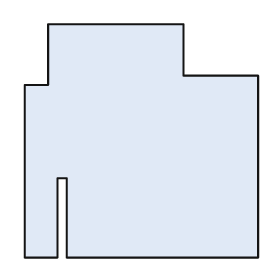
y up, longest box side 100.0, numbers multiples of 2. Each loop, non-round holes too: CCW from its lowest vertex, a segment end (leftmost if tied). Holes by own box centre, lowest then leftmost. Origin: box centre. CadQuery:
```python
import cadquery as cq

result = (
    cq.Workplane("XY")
    .moveTo(-50.0, -50.0)
    .lineTo(-36.0, -50.0)
    .lineTo(-36.0, -16.0)
    .lineTo(-32.0, -16.0)
    .lineTo(-32.0, -50.0)
    .lineTo(50.0, -50.0)
    .lineTo(50.0, 28.0)
    .lineTo(18.0, 28.0)
    .lineTo(18.0, 50.0)
    .lineTo(-40.0, 50.0)
    .lineTo(-40.0, 24.0)
    .lineTo(-50.0, 24.0)
    .close()
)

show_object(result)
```